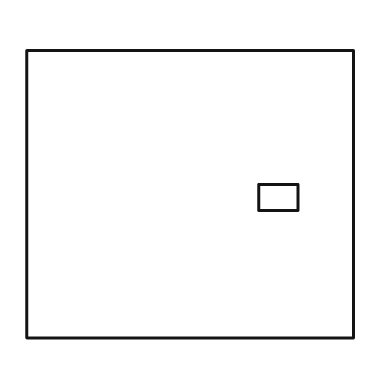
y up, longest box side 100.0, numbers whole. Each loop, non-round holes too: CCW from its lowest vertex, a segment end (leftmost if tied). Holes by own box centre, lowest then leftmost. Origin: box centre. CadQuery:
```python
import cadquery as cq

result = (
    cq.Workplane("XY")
    .moveTo(-50.0, -44.0)
    .lineTo(50.0, -44.0)
    .lineTo(50.0, 44.0)
    .lineTo(-50.0, 44.0)
    .close()
    .moveTo(21.0, -5.0)
    .lineTo(33.0, -5.0)
    .lineTo(33.0, 3.0)
    .lineTo(21.0, 3.0)
    .close()
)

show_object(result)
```